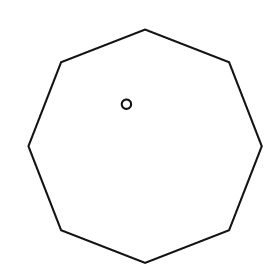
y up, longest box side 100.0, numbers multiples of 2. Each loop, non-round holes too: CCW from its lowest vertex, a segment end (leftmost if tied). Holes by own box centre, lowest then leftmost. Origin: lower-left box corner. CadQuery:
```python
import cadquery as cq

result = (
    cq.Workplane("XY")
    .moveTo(50.0, 0.0)
    .lineTo(86.0, 14.0)
    .lineTo(100.0, 50.0)
    .lineTo(86.0, 86.0)
    .lineTo(50.0, 100.0)
    .lineTo(14.0, 86.0)
    .lineTo(0.0, 50.0)
    .lineTo(14.0, 14.0)
    .close()
    .moveTo(42.0, 68.0)
    .circle(2.0)
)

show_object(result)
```